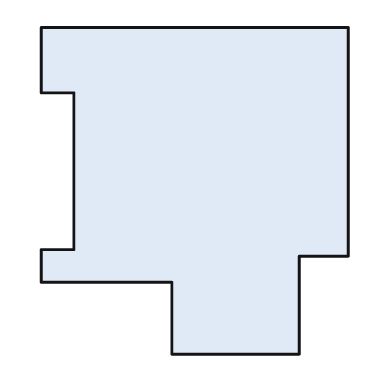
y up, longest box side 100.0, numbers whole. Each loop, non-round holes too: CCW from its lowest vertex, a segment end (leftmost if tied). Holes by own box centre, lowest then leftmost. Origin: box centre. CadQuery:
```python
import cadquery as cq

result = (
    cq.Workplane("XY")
    .moveTo(-7.0, -50.0)
    .lineTo(32.0, -50.0)
    .lineTo(32.0, -20.0)
    .lineTo(47.0, -20.0)
    .lineTo(47.0, 50.0)
    .lineTo(-47.0, 50.0)
    .lineTo(-47.0, 30.0)
    .lineTo(-37.0, 30.0)
    .lineTo(-37.0, -18.0)
    .lineTo(-47.0, -18.0)
    .lineTo(-47.0, -28.0)
    .lineTo(-7.0, -28.0)
    .close()
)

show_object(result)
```